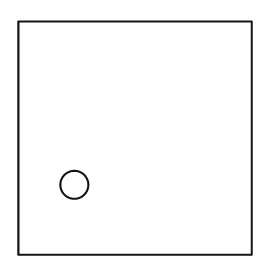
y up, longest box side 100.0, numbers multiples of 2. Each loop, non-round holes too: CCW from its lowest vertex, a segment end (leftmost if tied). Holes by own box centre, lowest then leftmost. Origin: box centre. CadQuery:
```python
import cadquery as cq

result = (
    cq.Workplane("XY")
    .moveTo(-50.0, -50.0)
    .lineTo(50.0, -50.0)
    .lineTo(50.0, 50.0)
    .lineTo(-50.0, 50.0)
    .close()
    .moveTo(-26.0, -20.0)
    .circle(6.0)
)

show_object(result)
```